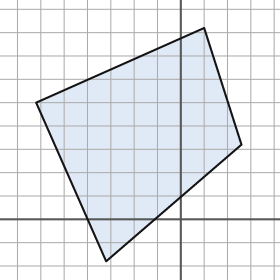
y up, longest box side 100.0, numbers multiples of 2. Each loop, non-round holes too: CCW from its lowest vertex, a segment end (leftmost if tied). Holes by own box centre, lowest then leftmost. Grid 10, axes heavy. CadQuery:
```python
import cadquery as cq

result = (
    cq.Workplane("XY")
    .moveTo(-32.0, -18.0)
    .lineTo(26.0, 32.0)
    .lineTo(10.0, 82.0)
    .lineTo(-62.0, 50.0)
    .close()
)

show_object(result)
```